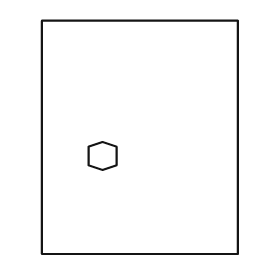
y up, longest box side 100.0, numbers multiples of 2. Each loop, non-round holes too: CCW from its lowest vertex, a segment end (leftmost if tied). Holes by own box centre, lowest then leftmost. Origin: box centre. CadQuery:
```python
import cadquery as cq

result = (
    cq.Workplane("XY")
    .moveTo(-42.0, -50.0)
    .lineTo(42.0, -50.0)
    .lineTo(42.0, 50.0)
    .lineTo(-42.0, 50.0)
    .close()
    .moveTo(-16.0, -14.0)
    .lineTo(-10.0, -12.0)
    .lineTo(-10.0, -4.0)
    .lineTo(-16.0, -2.0)
    .lineTo(-22.0, -4.0)
    .lineTo(-22.0, -12.0)
    .close()
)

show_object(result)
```